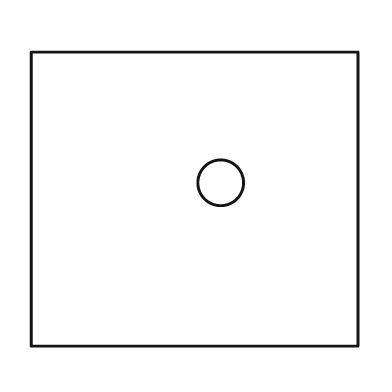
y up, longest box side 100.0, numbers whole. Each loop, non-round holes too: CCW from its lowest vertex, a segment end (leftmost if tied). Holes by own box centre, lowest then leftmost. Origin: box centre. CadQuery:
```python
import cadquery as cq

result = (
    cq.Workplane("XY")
    .moveTo(-50.0, -45.0)
    .lineTo(50.0, -45.0)
    .lineTo(50.0, 45.0)
    .lineTo(-50.0, 45.0)
    .close()
    .moveTo(8.0, 5.0)
    .circle(7.0)
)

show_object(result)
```